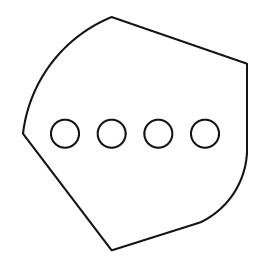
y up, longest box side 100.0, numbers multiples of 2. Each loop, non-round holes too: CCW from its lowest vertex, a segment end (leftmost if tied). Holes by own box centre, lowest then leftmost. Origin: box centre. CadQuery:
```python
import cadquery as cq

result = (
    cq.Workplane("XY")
    .moveTo(-10.0, -50.0)
    .lineTo(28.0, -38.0)
    .threePointArc((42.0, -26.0), (48.0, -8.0))
    .lineTo(48.0, 30.0)
    .lineTo(-10.0, 50.0)
    .threePointArc((-36.0, 30.0), (-48.0, 0.0))
    .close()
    .moveTo(-30.0, 0.0)
    .circle(6.0)
    .moveTo(-10.0, 0.0)
    .circle(6.0)
    .moveTo(10.0, 0.0)
    .circle(6.0)
    .moveTo(30.0, 0.0)
    .circle(6.0)
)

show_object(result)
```